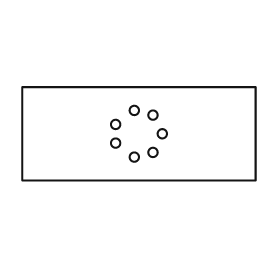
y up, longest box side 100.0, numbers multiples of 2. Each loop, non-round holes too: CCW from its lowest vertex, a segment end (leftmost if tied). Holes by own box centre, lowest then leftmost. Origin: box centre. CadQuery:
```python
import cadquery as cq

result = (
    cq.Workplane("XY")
    .moveTo(-50.0, -20.0)
    .lineTo(50.0, -20.0)
    .lineTo(50.0, 20.0)
    .lineTo(-50.0, 20.0)
    .close()
    .moveTo(-2.0, -10.0)
    .circle(2.0)
    .moveTo(6.0, -8.0)
    .circle(2.0)
    .moveTo(-10.0, -4.0)
    .circle(2.0)
    .moveTo(10.0, 0.0)
    .circle(2.0)
    .moveTo(-10.0, 4.0)
    .circle(2.0)
    .moveTo(6.0, 8.0)
    .circle(2.0)
    .moveTo(-2.0, 10.0)
    .circle(2.0)
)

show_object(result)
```